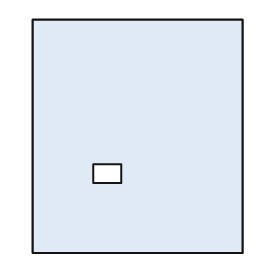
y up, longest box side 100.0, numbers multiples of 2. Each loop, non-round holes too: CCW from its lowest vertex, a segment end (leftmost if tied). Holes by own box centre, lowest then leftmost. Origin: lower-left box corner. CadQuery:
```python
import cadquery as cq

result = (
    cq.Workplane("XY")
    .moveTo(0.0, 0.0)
    .lineTo(90.0, 0.0)
    .lineTo(90.0, 100.0)
    .lineTo(0.0, 100.0)
    .close()
    .moveTo(26.0, 30.0)
    .lineTo(38.0, 30.0)
    .lineTo(38.0, 38.0)
    .lineTo(26.0, 38.0)
    .close()
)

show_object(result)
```